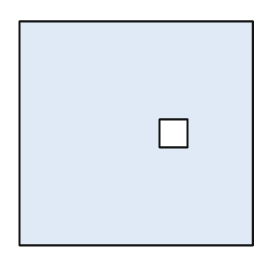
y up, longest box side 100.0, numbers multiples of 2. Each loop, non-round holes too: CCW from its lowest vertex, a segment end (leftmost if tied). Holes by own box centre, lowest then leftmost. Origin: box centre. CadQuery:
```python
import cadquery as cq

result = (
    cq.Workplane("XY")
    .moveTo(-50.0, -48.0)
    .lineTo(50.0, -48.0)
    .lineTo(50.0, 48.0)
    .lineTo(-50.0, 48.0)
    .close()
    .moveTo(10.0, -6.0)
    .lineTo(22.0, -6.0)
    .lineTo(22.0, 6.0)
    .lineTo(10.0, 6.0)
    .close()
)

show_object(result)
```